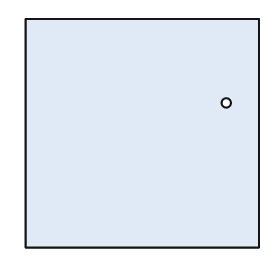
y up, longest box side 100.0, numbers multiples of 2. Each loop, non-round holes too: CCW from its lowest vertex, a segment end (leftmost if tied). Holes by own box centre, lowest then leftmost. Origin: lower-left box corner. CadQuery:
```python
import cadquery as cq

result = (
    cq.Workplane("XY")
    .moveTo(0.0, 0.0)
    .lineTo(100.0, 0.0)
    .lineTo(100.0, 98.0)
    .lineTo(0.0, 98.0)
    .close()
    .moveTo(86.0, 62.0)
    .circle(2.0)
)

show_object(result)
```